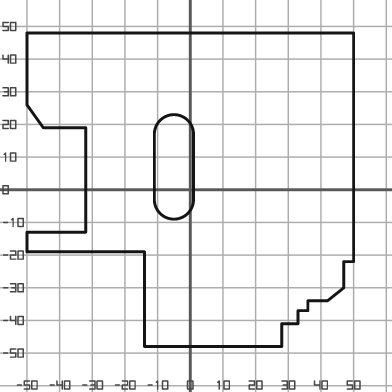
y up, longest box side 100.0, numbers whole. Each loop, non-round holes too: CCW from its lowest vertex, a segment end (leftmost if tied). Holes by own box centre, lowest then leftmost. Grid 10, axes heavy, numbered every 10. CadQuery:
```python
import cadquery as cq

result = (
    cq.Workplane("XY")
    .moveTo(-14.0, -48.0)
    .lineTo(28.0, -48.0)
    .lineTo(28.0, -41.0)
    .lineTo(33.0, -41.0)
    .lineTo(33.0, -37.0)
    .lineTo(36.0, -37.0)
    .lineTo(36.0, -34.0)
    .lineTo(42.0, -34.0)
    .lineTo(47.0, -30.0)
    .lineTo(47.0, -22.0)
    .lineTo(50.0, -22.0)
    .lineTo(50.0, 48.0)
    .lineTo(-50.0, 48.0)
    .lineTo(-50.0, 26.0)
    .lineTo(-45.0, 19.0)
    .lineTo(-32.0, 19.0)
    .lineTo(-32.0, -13.0)
    .lineTo(-50.0, -13.0)
    .lineTo(-50.0, -19.0)
    .lineTo(-14.0, -19.0)
    .close()
    .moveTo(-11.0, -3.0)
    .threePointArc((-5.0, -9.0), (1.0, -3.0))
    .lineTo(1.0, 17.0)
    .threePointArc((-5.0, 23.0), (-11.0, 17.0))
    .close()
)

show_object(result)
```